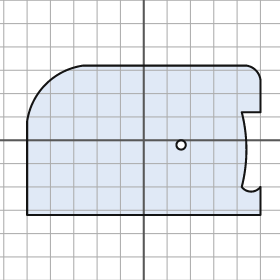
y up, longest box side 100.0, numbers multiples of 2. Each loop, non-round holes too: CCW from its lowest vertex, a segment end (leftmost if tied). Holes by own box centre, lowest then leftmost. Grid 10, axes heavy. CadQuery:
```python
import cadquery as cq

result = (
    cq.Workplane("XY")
    .moveTo(-50.0, -32.0)
    .lineTo(50.0, -32.0)
    .lineTo(50.0, -20.0)
    .threePointArc((46.0, -22.0), (42.0, -20.0))
    .threePointArc((44.0, -4.0), (42.0, 12.0))
    .lineTo(50.0, 12.0)
    .lineTo(50.0, 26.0)
    .threePointArc((48.0, 30.0), (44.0, 32.0))
    .lineTo(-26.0, 32.0)
    .threePointArc((-42.0, 24.0), (-50.0, 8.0))
    .close()
    .moveTo(16.0, -2.0)
    .circle(2.0)
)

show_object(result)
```